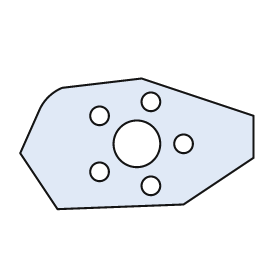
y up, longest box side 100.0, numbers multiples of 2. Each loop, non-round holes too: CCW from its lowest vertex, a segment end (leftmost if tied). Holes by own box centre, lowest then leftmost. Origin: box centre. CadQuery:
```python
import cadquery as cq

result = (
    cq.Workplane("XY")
    .moveTo(-34.0, -28.0)
    .lineTo(20.0, -26.0)
    .lineTo(50.0, -6.0)
    .lineTo(50.0, 12.0)
    .lineTo(2.0, 28.0)
    .lineTo(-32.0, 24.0)
    .threePointArc((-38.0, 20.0), (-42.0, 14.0))
    .lineTo(-50.0, -4.0)
    .close()
    .moveTo(6.0, -18.0)
    .circle(4.0)
    .moveTo(-16.0, -12.0)
    .circle(4.0)
    .moveTo(0.0, 0.0)
    .circle(10.0)
    .moveTo(20.0, 0.0)
    .circle(4.0)
    .moveTo(-16.0, 12.0)
    .circle(4.0)
    .moveTo(6.0, 18.0)
    .circle(4.0)
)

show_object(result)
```